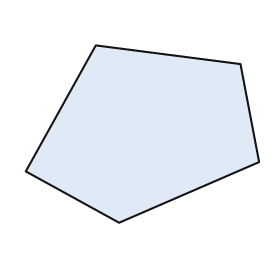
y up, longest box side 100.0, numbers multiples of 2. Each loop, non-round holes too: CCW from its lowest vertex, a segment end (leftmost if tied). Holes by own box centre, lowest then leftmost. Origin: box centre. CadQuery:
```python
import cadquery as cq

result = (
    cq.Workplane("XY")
    .moveTo(-10.0, -38.0)
    .lineTo(50.0, -12.0)
    .lineTo(42.0, 30.0)
    .lineTo(-20.0, 38.0)
    .lineTo(-50.0, -16.0)
    .close()
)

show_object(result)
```